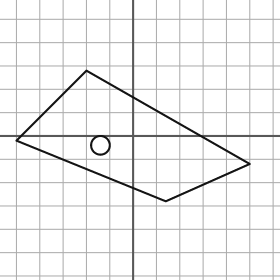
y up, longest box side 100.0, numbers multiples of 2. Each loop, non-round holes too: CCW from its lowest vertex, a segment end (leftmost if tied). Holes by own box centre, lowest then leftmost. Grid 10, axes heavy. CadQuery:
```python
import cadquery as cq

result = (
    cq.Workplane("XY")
    .moveTo(14.0, -28.0)
    .lineTo(50.0, -12.0)
    .lineTo(-20.0, 28.0)
    .lineTo(-50.0, -2.0)
    .close()
    .moveTo(-14.0, -4.0)
    .circle(4.0)
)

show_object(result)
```